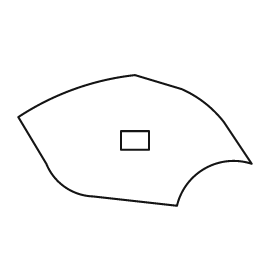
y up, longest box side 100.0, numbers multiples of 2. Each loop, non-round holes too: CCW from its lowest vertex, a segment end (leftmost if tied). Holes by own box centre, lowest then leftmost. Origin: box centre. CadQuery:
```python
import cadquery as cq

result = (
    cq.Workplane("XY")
    .moveTo(18.0, -28.0)
    .threePointArc((30.0, -12.0), (50.0, -10.0))
    .lineTo(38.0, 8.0)
    .threePointArc((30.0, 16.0), (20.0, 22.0))
    .lineTo(0.0, 28.0)
    .threePointArc((-26.0, 22.0), (-50.0, 10.0))
    .lineTo(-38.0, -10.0)
    .threePointArc((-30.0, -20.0), (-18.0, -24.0))
    .close()
    .moveTo(-6.0, -4.0)
    .lineTo(6.0, -4.0)
    .lineTo(6.0, 4.0)
    .lineTo(-6.0, 4.0)
    .close()
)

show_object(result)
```